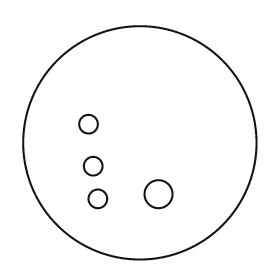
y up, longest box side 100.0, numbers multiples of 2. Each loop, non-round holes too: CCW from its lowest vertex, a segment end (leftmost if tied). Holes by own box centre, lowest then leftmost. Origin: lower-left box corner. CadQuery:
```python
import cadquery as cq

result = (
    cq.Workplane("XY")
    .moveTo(50.0, 50.0)
    .circle(50.0)
    .moveTo(32.0, 26.0)
    .circle(4.0)
    .moveTo(58.0, 28.0)
    .circle(6.0)
    .moveTo(30.0, 40.0)
    .circle(4.0)
    .moveTo(28.0, 58.0)
    .circle(4.0)
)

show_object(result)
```